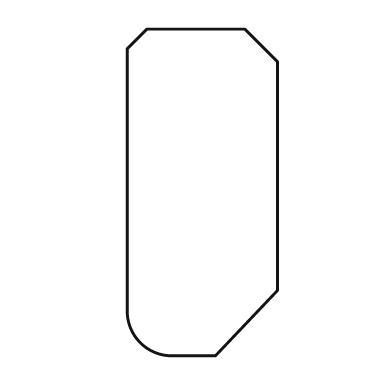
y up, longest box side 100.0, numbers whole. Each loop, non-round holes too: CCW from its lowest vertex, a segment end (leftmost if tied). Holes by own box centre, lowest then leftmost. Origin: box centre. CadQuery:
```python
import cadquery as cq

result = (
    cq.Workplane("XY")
    .moveTo(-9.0, -50.0)
    .lineTo(4.0, -50.0)
    .lineTo(23.0, -30.0)
    .lineTo(23.0, 40.0)
    .lineTo(13.0, 50.0)
    .lineTo(-17.0, 50.0)
    .lineTo(-23.0, 44.0)
    .lineTo(-23.0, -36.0)
    .threePointArc((-19.0, -46.0), (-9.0, -50.0))
    .close()
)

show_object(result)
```